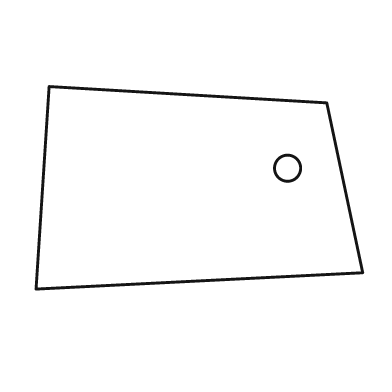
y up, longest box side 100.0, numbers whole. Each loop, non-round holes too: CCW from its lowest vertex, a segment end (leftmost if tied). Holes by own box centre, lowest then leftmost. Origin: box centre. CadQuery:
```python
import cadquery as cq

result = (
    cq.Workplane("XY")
    .moveTo(-50.0, -31.0)
    .lineTo(50.0, -26.0)
    .lineTo(39.0, 26.0)
    .lineTo(-46.0, 31.0)
    .close()
    .moveTo(27.0, 6.0)
    .circle(4.0)
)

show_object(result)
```